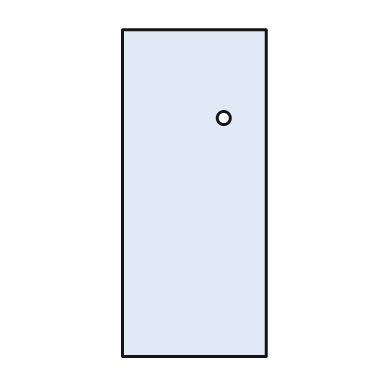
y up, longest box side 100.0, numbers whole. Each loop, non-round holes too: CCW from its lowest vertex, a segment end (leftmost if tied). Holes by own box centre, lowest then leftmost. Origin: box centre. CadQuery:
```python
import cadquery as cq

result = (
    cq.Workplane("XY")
    .moveTo(-22.0, -50.0)
    .lineTo(22.0, -50.0)
    .lineTo(22.0, 50.0)
    .lineTo(-22.0, 50.0)
    .close()
    .moveTo(9.0, 23.0)
    .circle(2.0)
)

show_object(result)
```